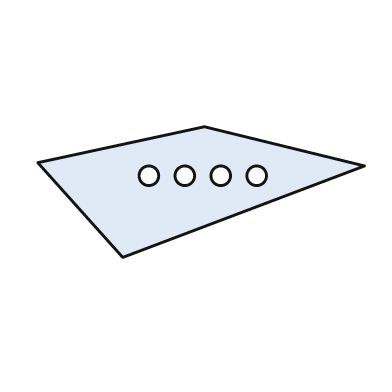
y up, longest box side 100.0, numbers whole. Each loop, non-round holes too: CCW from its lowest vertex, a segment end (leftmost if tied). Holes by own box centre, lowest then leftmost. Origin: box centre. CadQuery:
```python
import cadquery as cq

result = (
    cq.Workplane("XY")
    .moveTo(-24.0, -20.0)
    .lineTo(50.0, 8.0)
    .lineTo(1.0, 20.0)
    .lineTo(-50.0, 9.0)
    .close()
    .moveTo(-16.0, 5.0)
    .circle(3.0)
    .moveTo(-5.0, 5.0)
    .circle(3.0)
    .moveTo(6.0, 5.0)
    .circle(3.0)
    .moveTo(17.0, 5.0)
    .circle(3.0)
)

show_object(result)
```